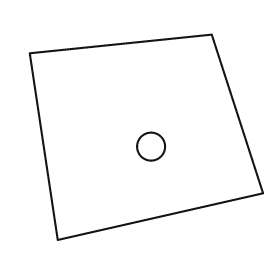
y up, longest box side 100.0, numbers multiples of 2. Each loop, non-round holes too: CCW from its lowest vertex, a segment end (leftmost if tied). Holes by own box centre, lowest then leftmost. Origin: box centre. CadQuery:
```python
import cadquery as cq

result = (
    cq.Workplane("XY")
    .moveTo(-38.0, -44.0)
    .lineTo(50.0, -24.0)
    .lineTo(28.0, 44.0)
    .lineTo(-50.0, 36.0)
    .close()
    .moveTo(2.0, -4.0)
    .circle(6.0)
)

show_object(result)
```